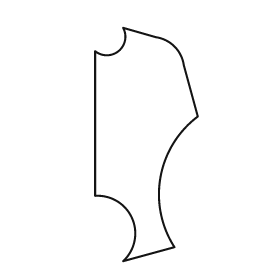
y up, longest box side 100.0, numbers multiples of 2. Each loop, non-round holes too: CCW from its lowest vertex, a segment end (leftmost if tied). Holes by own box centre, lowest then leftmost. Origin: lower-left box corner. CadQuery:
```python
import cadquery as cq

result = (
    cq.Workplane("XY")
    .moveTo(12.0, 0.0)
    .lineTo(34.0, 6.0)
    .threePointArc((28.0, 36.0), (44.0, 62.0))
    .lineTo(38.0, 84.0)
    .threePointArc((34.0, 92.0), (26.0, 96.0))
    .lineTo(12.0, 100.0)
    .threePointArc((10.0, 90.0), (0.0, 90.0))
    .lineTo(0.0, 28.0)
    .threePointArc((16.0, 18.0), (12.0, 0.0))
    .close()
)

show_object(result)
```